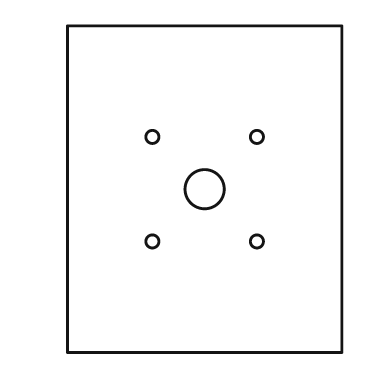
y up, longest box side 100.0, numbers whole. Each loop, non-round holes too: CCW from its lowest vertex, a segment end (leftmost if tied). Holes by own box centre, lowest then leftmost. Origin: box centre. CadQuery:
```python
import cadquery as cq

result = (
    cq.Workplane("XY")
    .moveTo(-42.0, -50.0)
    .lineTo(42.0, -50.0)
    .lineTo(42.0, 50.0)
    .lineTo(-42.0, 50.0)
    .close()
    .moveTo(-16.0, -16.0)
    .circle(2.0)
    .moveTo(16.0, -16.0)
    .circle(2.0)
    .moveTo(0.0, 0.0)
    .circle(6.0)
    .moveTo(-16.0, 16.0)
    .circle(2.0)
    .moveTo(16.0, 16.0)
    .circle(2.0)
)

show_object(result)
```